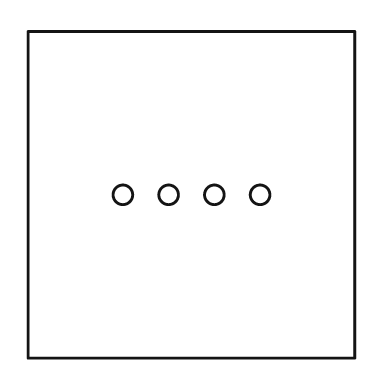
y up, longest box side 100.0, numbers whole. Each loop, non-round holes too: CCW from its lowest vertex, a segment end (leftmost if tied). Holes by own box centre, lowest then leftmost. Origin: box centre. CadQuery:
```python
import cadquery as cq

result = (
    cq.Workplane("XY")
    .moveTo(-50.0, -50.0)
    .lineTo(50.0, -50.0)
    .lineTo(50.0, 50.0)
    .lineTo(-50.0, 50.0)
    .close()
    .moveTo(-21.0, 0.0)
    .circle(3.0)
    .moveTo(-7.0, 0.0)
    .circle(3.0)
    .moveTo(7.0, 0.0)
    .circle(3.0)
    .moveTo(21.0, 0.0)
    .circle(3.0)
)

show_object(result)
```